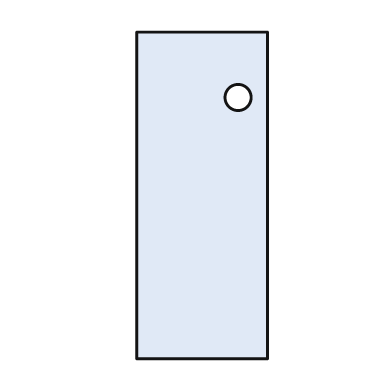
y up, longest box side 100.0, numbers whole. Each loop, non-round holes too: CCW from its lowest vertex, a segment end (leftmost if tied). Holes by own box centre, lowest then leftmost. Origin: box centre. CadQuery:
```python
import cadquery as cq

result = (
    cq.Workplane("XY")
    .moveTo(-20.0, -50.0)
    .lineTo(20.0, -50.0)
    .lineTo(20.0, 50.0)
    .lineTo(-20.0, 50.0)
    .close()
    .moveTo(11.0, 30.0)
    .circle(4.0)
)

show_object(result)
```